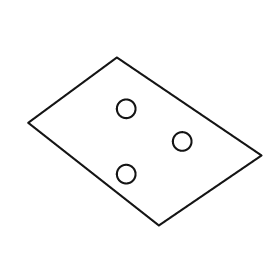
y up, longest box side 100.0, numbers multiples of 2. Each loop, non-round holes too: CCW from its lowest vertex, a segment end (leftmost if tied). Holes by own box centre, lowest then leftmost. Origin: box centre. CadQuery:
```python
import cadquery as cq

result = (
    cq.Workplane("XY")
    .moveTo(6.0, -36.0)
    .lineTo(50.0, -6.0)
    .lineTo(-12.0, 36.0)
    .lineTo(-50.0, 8.0)
    .close()
    .moveTo(-8.0, -14.0)
    .circle(4.0)
    .moveTo(16.0, 0.0)
    .circle(4.0)
    .moveTo(-8.0, 14.0)
    .circle(4.0)
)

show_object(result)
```